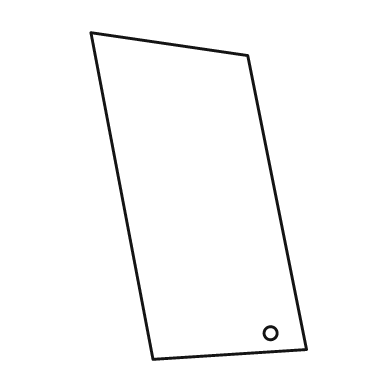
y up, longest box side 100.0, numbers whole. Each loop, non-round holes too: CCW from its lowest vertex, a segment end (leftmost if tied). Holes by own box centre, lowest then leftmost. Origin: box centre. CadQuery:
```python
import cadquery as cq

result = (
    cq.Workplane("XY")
    .moveTo(-14.0, -50.0)
    .lineTo(33.0, -47.0)
    .lineTo(15.0, 43.0)
    .lineTo(-33.0, 50.0)
    .close()
    .moveTo(22.0, -42.0)
    .circle(2.0)
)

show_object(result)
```